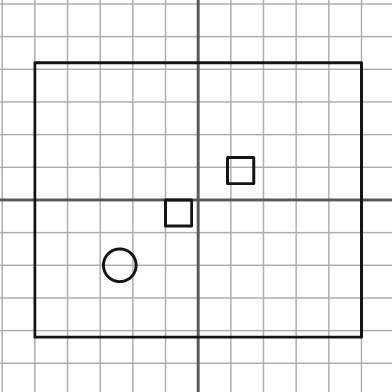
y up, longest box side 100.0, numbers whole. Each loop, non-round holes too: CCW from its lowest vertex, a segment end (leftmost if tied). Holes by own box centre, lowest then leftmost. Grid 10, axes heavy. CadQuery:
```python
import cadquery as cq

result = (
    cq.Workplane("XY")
    .moveTo(-50.0, -42.0)
    .lineTo(50.0, -42.0)
    .lineTo(50.0, 42.0)
    .lineTo(-50.0, 42.0)
    .close()
    .moveTo(-24.0, -20.0)
    .circle(5.0)
    .moveTo(-10.0, -8.0)
    .lineTo(-2.0, -8.0)
    .lineTo(-2.0, 0.0)
    .lineTo(-10.0, 0.0)
    .close()
    .moveTo(9.0, 5.0)
    .lineTo(17.0, 5.0)
    .lineTo(17.0, 13.0)
    .lineTo(9.0, 13.0)
    .close()
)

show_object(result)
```